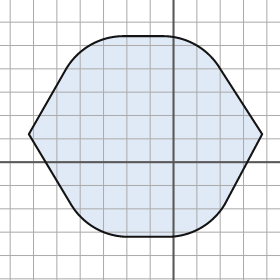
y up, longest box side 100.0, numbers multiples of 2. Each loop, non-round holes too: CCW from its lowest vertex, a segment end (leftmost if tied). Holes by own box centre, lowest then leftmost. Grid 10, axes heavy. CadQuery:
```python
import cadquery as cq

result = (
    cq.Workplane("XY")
    .moveTo(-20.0, -32.0)
    .lineTo(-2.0, -32.0)
    .threePointArc((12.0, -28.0), (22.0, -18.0))
    .lineTo(38.0, 12.0)
    .lineTo(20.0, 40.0)
    .threePointArc((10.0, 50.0), (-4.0, 54.0))
    .lineTo(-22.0, 54.0)
    .threePointArc((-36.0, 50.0), (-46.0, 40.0))
    .lineTo(-62.0, 12.0)
    .lineTo(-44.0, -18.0)
    .threePointArc((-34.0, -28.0), (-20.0, -32.0))
    .close()
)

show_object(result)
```